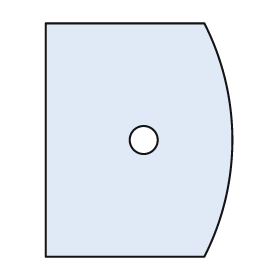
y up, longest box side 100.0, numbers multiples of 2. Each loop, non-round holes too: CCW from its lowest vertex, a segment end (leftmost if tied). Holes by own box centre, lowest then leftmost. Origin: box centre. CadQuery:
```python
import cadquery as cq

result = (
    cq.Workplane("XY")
    .moveTo(-40.0, -50.0)
    .lineTo(28.0, -50.0)
    .threePointArc((40.0, 0.0), (28.0, 50.0))
    .lineTo(-40.0, 50.0)
    .close()
    .moveTo(2.0, 0.0)
    .circle(6.0)
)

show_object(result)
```